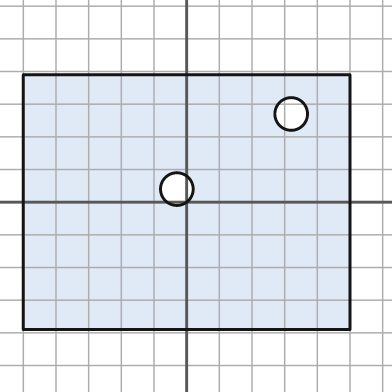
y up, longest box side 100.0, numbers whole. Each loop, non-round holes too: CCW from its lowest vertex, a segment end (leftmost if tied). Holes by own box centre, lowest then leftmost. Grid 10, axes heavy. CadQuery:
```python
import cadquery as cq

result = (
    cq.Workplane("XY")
    .moveTo(-50.0, -39.0)
    .lineTo(50.0, -39.0)
    .lineTo(50.0, 39.0)
    .lineTo(-50.0, 39.0)
    .close()
    .moveTo(-3.0, 4.0)
    .circle(5.0)
    .moveTo(32.0, 27.0)
    .circle(5.0)
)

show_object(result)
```